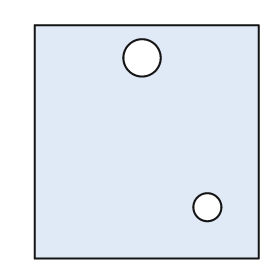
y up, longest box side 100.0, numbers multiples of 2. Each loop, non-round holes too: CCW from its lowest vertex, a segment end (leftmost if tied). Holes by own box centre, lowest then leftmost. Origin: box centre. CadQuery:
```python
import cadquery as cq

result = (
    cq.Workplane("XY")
    .moveTo(-48.0, -50.0)
    .lineTo(48.0, -50.0)
    .lineTo(48.0, 50.0)
    .lineTo(-48.0, 50.0)
    .close()
    .moveTo(26.0, -28.0)
    .circle(6.0)
    .moveTo(-2.0, 36.0)
    .circle(8.0)
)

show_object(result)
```